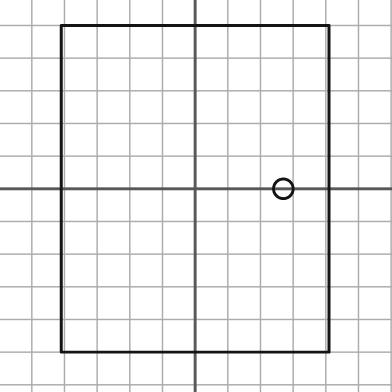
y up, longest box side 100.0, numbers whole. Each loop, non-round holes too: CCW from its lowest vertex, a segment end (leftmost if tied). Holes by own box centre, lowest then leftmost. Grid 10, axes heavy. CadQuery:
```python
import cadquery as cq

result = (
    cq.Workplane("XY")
    .moveTo(-41.0, -50.0)
    .lineTo(41.0, -50.0)
    .lineTo(41.0, 50.0)
    .lineTo(-41.0, 50.0)
    .close()
    .moveTo(27.0, 0.0)
    .circle(3.0)
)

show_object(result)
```